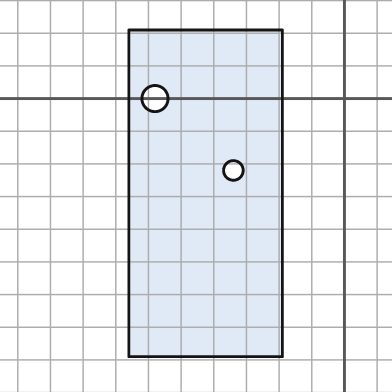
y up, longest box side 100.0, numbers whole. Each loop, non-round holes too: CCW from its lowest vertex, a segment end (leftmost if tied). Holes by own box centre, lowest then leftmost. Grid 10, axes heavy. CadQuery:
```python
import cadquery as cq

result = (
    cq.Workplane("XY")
    .moveTo(-66.0, -79.0)
    .lineTo(-19.0, -79.0)
    .lineTo(-19.0, 21.0)
    .lineTo(-66.0, 21.0)
    .close()
    .moveTo(-34.0, -22.0)
    .circle(3.0)
    .moveTo(-58.0, 0.0)
    .circle(4.0)
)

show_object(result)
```